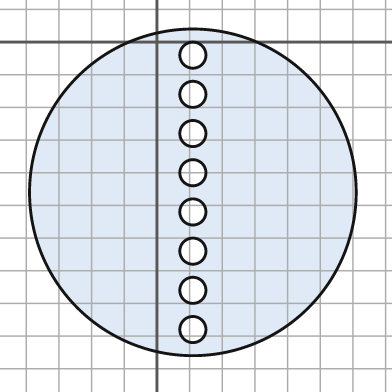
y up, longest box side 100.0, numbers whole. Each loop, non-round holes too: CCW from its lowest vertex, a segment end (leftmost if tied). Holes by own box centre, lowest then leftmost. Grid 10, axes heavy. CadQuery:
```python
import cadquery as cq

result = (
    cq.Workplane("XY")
    .moveTo(11.0, -46.0)
    .circle(50.0)
    .moveTo(11.0, -88.0)
    .circle(4.0)
    .moveTo(11.0, -76.0)
    .circle(4.0)
    .moveTo(11.0, -64.0)
    .circle(4.0)
    .moveTo(11.0, -52.0)
    .circle(4.0)
    .moveTo(11.0, -40.0)
    .circle(4.0)
    .moveTo(11.0, -28.0)
    .circle(4.0)
    .moveTo(11.0, -16.0)
    .circle(4.0)
    .moveTo(11.0, -4.0)
    .circle(4.0)
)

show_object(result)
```